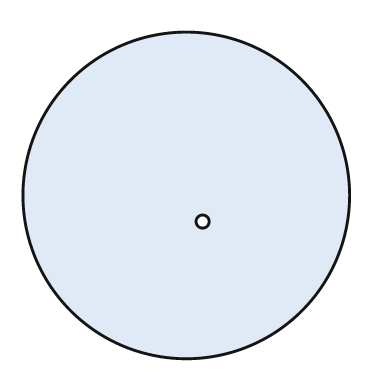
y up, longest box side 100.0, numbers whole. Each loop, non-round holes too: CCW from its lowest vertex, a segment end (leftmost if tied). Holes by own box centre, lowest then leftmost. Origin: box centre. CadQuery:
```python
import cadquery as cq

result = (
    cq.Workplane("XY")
    .moveTo(0.0, 0.0)
    .circle(50.0)
    .moveTo(5.0, -8.0)
    .circle(2.0)
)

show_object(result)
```